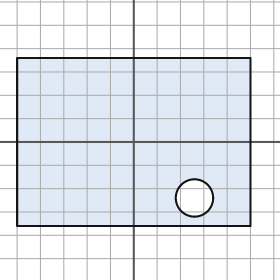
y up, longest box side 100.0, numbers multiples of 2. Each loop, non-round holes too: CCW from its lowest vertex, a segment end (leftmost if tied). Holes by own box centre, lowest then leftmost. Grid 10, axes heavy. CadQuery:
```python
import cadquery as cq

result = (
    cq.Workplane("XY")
    .moveTo(-50.0, -36.0)
    .lineTo(50.0, -36.0)
    .lineTo(50.0, 36.0)
    .lineTo(-50.0, 36.0)
    .close()
    .moveTo(26.0, -24.0)
    .circle(8.0)
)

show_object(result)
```